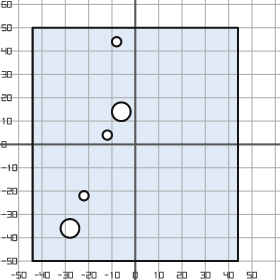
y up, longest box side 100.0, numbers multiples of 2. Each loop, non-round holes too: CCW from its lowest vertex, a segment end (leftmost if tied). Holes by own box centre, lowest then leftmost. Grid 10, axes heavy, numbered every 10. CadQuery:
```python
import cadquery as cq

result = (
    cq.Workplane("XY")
    .moveTo(-44.0, -50.0)
    .lineTo(44.0, -50.0)
    .lineTo(44.0, 50.0)
    .lineTo(-44.0, 50.0)
    .close()
    .moveTo(-28.0, -36.0)
    .circle(4.0)
    .moveTo(-22.0, -22.0)
    .circle(2.0)
    .moveTo(-12.0, 4.0)
    .circle(2.0)
    .moveTo(-6.0, 14.0)
    .circle(4.0)
    .moveTo(-8.0, 44.0)
    .circle(2.0)
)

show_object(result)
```